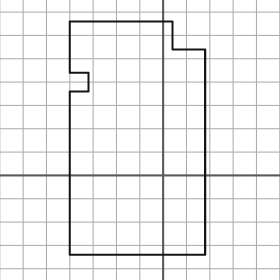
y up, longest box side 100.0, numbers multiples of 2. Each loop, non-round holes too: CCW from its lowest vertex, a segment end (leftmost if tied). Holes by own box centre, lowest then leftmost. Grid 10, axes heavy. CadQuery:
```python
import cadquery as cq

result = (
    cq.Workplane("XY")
    .moveTo(-40.0, -34.0)
    .lineTo(18.0, -34.0)
    .lineTo(18.0, 54.0)
    .lineTo(4.0, 54.0)
    .lineTo(4.0, 66.0)
    .lineTo(-40.0, 66.0)
    .lineTo(-40.0, 44.0)
    .lineTo(-32.0, 44.0)
    .lineTo(-32.0, 36.0)
    .lineTo(-40.0, 36.0)
    .close()
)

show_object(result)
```